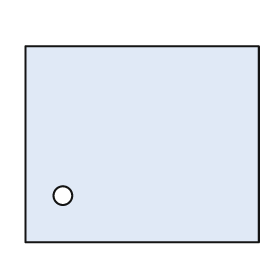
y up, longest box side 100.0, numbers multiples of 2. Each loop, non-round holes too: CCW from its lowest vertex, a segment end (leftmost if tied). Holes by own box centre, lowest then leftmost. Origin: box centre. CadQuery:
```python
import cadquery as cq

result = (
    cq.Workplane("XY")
    .moveTo(-50.0, -42.0)
    .lineTo(50.0, -42.0)
    .lineTo(50.0, 42.0)
    .lineTo(-50.0, 42.0)
    .close()
    .moveTo(-34.0, -22.0)
    .circle(4.0)
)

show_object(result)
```